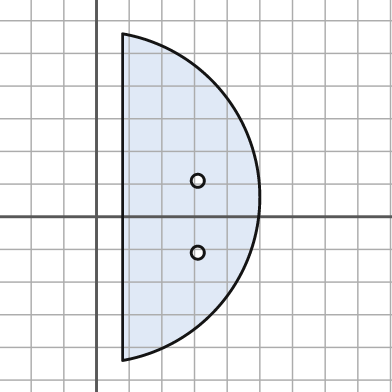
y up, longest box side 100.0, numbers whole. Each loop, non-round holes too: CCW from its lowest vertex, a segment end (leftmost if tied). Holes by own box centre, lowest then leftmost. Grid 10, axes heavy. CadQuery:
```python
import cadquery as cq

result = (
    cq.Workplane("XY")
    .moveTo(8.0, -44.0)
    .threePointArc((50.0, 6.0), (8.0, 56.0))
    .close()
    .moveTo(31.0, -11.0)
    .circle(2.0)
    .moveTo(31.0, 11.0)
    .circle(2.0)
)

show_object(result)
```